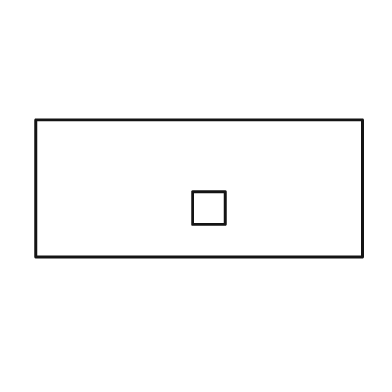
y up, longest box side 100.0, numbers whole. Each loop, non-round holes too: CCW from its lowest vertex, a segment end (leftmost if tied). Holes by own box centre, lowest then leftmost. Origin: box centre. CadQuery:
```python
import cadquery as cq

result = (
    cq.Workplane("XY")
    .moveTo(-50.0, -21.0)
    .lineTo(50.0, -21.0)
    .lineTo(50.0, 21.0)
    .lineTo(-50.0, 21.0)
    .close()
    .moveTo(-2.0, -11.0)
    .lineTo(8.0, -11.0)
    .lineTo(8.0, -1.0)
    .lineTo(-2.0, -1.0)
    .close()
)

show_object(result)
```